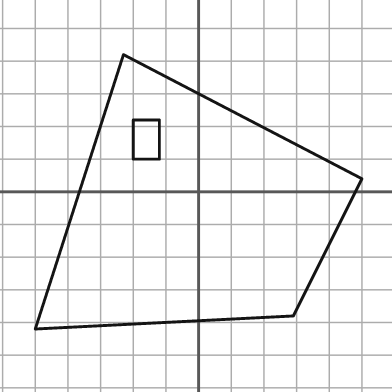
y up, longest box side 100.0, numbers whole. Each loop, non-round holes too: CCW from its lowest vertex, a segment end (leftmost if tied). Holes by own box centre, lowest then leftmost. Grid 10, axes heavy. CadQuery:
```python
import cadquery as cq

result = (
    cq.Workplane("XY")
    .moveTo(-50.0, -42.0)
    .lineTo(29.0, -38.0)
    .lineTo(50.0, 4.0)
    .lineTo(-23.0, 42.0)
    .close()
    .moveTo(-20.0, 10.0)
    .lineTo(-12.0, 10.0)
    .lineTo(-12.0, 22.0)
    .lineTo(-20.0, 22.0)
    .close()
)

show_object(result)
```